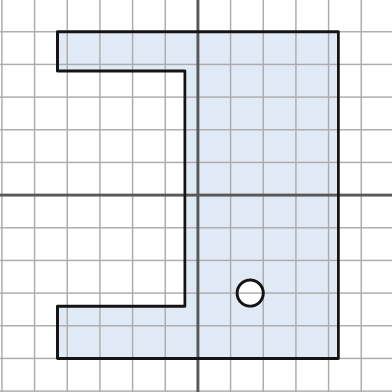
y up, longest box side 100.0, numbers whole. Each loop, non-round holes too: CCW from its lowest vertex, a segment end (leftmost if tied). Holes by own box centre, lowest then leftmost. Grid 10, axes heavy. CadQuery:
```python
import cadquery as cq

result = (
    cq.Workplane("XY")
    .moveTo(-43.0, -50.0)
    .lineTo(43.0, -50.0)
    .lineTo(43.0, 50.0)
    .lineTo(-43.0, 50.0)
    .lineTo(-43.0, 38.0)
    .lineTo(-4.0, 38.0)
    .lineTo(-4.0, -34.0)
    .lineTo(-43.0, -34.0)
    .close()
    .moveTo(16.0, -30.0)
    .circle(4.0)
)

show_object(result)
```